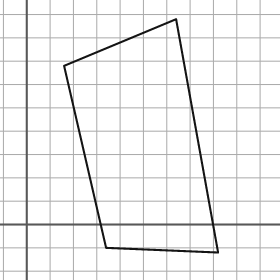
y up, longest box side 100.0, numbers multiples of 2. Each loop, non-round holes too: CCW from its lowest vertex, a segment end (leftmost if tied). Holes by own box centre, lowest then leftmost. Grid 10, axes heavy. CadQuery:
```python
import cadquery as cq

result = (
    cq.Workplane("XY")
    .moveTo(82.0, -12.0)
    .lineTo(64.0, 88.0)
    .lineTo(16.0, 68.0)
    .lineTo(34.0, -10.0)
    .close()
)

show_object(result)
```